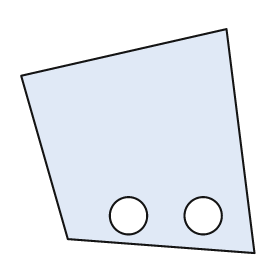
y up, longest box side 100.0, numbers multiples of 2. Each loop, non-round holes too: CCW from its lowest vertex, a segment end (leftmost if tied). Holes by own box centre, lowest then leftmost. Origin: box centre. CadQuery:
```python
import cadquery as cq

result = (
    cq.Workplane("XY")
    .moveTo(50.0, -48.0)
    .lineTo(38.0, 48.0)
    .lineTo(-50.0, 28.0)
    .lineTo(-30.0, -42.0)
    .close()
    .moveTo(-4.0, -32.0)
    .circle(8.0)
    .moveTo(28.0, -32.0)
    .circle(8.0)
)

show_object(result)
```